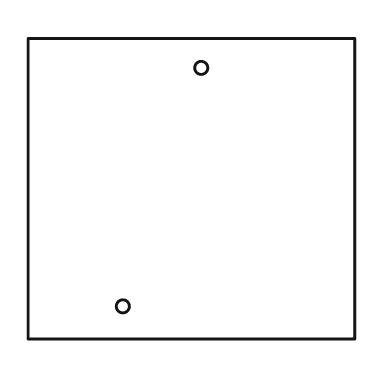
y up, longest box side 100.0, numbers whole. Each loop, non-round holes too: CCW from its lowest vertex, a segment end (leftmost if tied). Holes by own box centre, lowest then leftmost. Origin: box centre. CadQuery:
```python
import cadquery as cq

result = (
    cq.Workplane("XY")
    .moveTo(-50.0, -46.0)
    .lineTo(50.0, -46.0)
    .lineTo(50.0, 46.0)
    .lineTo(-50.0, 46.0)
    .close()
    .moveTo(-21.0, -36.0)
    .circle(2.0)
    .moveTo(3.0, 37.0)
    .circle(2.0)
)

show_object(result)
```